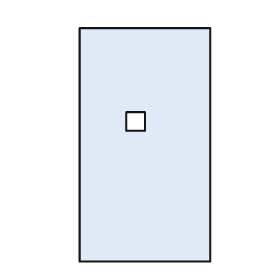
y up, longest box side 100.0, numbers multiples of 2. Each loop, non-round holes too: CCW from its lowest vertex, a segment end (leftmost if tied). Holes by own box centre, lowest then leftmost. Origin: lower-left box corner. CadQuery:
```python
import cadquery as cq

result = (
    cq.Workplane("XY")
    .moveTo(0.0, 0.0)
    .lineTo(56.0, 0.0)
    .lineTo(56.0, 100.0)
    .lineTo(0.0, 100.0)
    .close()
    .moveTo(20.0, 56.0)
    .lineTo(28.0, 56.0)
    .lineTo(28.0, 64.0)
    .lineTo(20.0, 64.0)
    .close()
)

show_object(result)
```